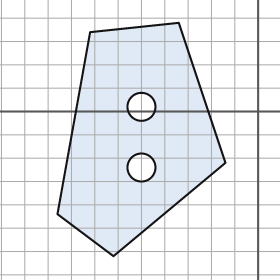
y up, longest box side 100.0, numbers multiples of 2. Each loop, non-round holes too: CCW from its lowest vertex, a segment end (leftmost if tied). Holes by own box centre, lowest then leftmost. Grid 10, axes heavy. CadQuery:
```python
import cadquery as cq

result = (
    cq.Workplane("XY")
    .moveTo(-62.0, -62.0)
    .lineTo(-14.0, -22.0)
    .lineTo(-34.0, 38.0)
    .lineTo(-72.0, 34.0)
    .lineTo(-86.0, -44.0)
    .close()
    .moveTo(-50.0, -24.0)
    .circle(6.0)
    .moveTo(-50.0, 2.0)
    .circle(6.0)
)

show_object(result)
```